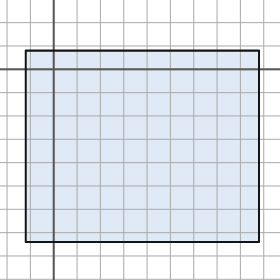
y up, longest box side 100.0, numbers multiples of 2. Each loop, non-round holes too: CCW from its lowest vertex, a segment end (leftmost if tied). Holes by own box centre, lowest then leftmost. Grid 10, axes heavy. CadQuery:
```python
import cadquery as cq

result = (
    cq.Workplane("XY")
    .moveTo(-12.0, -74.0)
    .lineTo(88.0, -74.0)
    .lineTo(88.0, 8.0)
    .lineTo(-12.0, 8.0)
    .close()
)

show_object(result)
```